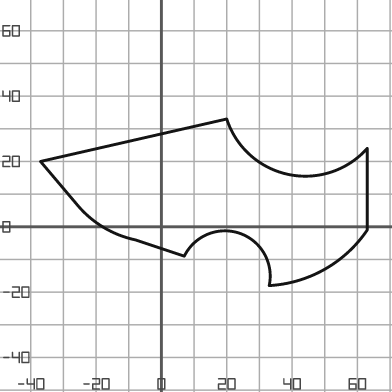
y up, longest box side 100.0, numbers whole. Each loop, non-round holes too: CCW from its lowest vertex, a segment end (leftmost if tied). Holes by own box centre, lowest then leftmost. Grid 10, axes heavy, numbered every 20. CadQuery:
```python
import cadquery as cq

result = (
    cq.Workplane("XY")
    .moveTo(33.0, -18.0)
    .threePointArc((50.0, -13.0), (63.0, -1.0))
    .lineTo(63.0, 24.0)
    .threePointArc((39.0, 16.0), (20.0, 33.0))
    .lineTo(-37.0, 20.0)
    .lineTo(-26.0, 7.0)
    .threePointArc((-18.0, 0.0), (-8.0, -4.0))
    .lineTo(7.0, -9.0)
    .threePointArc((24.0, -2.0), (33.0, -18.0))
    .close()
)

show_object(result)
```